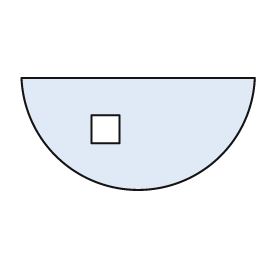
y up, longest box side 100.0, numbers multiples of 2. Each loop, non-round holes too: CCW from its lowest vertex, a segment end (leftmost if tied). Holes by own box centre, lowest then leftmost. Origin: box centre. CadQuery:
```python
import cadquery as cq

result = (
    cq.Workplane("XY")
    .moveTo(-50.0, 24.0)
    .threePointArc((0.0, -24.0), (50.0, 24.0))
    .close()
    .moveTo(-20.0, -4.0)
    .lineTo(-8.0, -4.0)
    .lineTo(-8.0, 8.0)
    .lineTo(-20.0, 8.0)
    .close()
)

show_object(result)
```